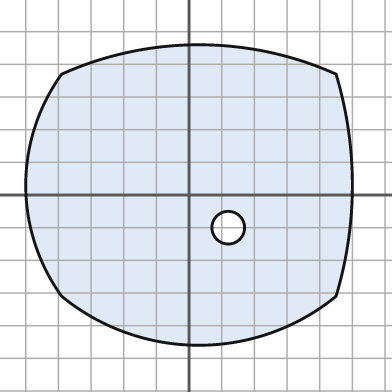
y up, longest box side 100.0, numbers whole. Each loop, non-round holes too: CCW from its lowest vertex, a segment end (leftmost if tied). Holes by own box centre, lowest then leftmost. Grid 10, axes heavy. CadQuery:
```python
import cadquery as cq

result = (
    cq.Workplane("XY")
    .moveTo(-39.0, -31.0)
    .threePointArc((3.0, -46.0), (45.0, -31.0))
    .threePointArc((50.0, 3.0), (45.0, 37.0))
    .threePointArc((3.0, 46.0), (-39.0, 37.0))
    .threePointArc((-50.0, 3.0), (-39.0, -31.0))
    .close()
    .moveTo(12.0, -10.0)
    .circle(5.0)
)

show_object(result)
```